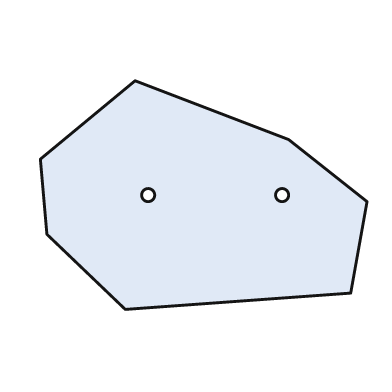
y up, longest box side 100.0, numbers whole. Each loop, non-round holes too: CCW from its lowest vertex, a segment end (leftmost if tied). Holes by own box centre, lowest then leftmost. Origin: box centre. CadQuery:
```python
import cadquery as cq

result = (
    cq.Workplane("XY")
    .moveTo(-24.0, -35.0)
    .lineTo(45.0, -30.0)
    .lineTo(50.0, -2.0)
    .lineTo(26.0, 17.0)
    .lineTo(-21.0, 35.0)
    .lineTo(-50.0, 11.0)
    .lineTo(-48.0, -12.0)
    .close()
    .moveTo(-17.0, 0.0)
    .circle(2.0)
    .moveTo(24.0, 0.0)
    .circle(2.0)
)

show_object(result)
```